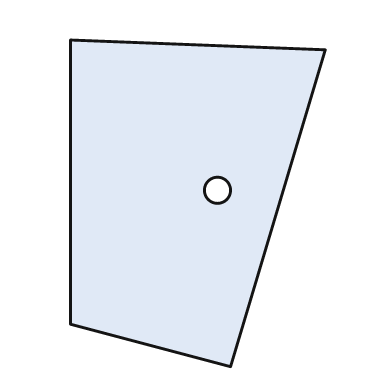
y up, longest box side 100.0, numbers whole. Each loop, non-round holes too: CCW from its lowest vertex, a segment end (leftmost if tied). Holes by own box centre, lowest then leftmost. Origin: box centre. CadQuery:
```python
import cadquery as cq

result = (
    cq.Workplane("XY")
    .moveTo(10.0, -50.0)
    .lineTo(39.0, 47.0)
    .lineTo(-39.0, 50.0)
    .lineTo(-39.0, -37.0)
    .close()
    .moveTo(6.0, 4.0)
    .circle(4.0)
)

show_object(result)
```